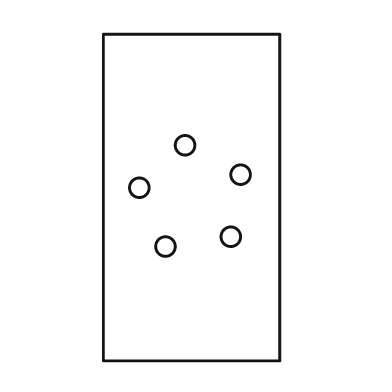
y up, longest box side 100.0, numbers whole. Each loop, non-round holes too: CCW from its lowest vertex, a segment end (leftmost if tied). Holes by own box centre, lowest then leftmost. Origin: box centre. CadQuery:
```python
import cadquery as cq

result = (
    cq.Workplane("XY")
    .moveTo(-27.0, -50.0)
    .lineTo(27.0, -50.0)
    .lineTo(27.0, 50.0)
    .lineTo(-27.0, 50.0)
    .close()
    .moveTo(-8.0, -15.0)
    .circle(3.0)
    .moveTo(12.0, -12.0)
    .circle(3.0)
    .moveTo(-16.0, 3.0)
    .circle(3.0)
    .moveTo(15.0, 7.0)
    .circle(3.0)
    .moveTo(-2.0, 16.0)
    .circle(3.0)
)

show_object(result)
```